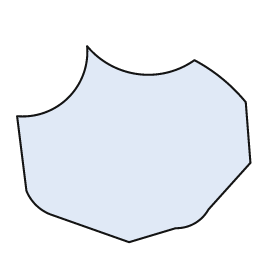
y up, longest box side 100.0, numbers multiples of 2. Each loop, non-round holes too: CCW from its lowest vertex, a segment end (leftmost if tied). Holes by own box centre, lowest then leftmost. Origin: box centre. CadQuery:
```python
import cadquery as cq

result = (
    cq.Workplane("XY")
    .moveTo(-2.0, -42.0)
    .lineTo(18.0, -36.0)
    .threePointArc((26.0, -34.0), (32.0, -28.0))
    .lineTo(50.0, -8.0)
    .lineTo(48.0, 18.0)
    .threePointArc((38.0, 28.0), (26.0, 36.0))
    .threePointArc((2.0, 30.0), (-20.0, 42.0))
    .threePointArc((-28.0, 20.0), (-50.0, 12.0))
    .lineTo(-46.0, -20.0)
    .threePointArc((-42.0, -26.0), (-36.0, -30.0))
    .close()
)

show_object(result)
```